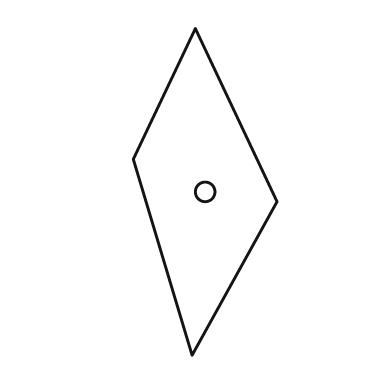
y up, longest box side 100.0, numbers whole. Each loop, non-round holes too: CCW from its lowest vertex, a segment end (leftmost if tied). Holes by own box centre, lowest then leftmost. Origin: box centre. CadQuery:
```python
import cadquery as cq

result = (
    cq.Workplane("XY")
    .moveTo(-4.0, -50.0)
    .lineTo(22.0, -3.0)
    .lineTo(-3.0, 50.0)
    .lineTo(-22.0, 10.0)
    .close()
    .moveTo(0.0, 0.0)
    .circle(3.0)
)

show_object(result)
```